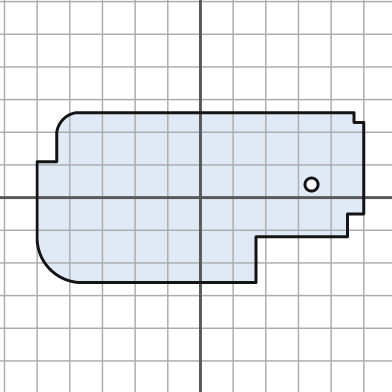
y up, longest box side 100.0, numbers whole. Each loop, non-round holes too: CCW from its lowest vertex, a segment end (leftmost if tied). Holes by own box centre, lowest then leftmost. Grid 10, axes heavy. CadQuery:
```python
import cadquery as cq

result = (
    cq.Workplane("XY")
    .moveTo(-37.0, -26.0)
    .lineTo(17.0, -26.0)
    .lineTo(17.0, -12.0)
    .lineTo(45.0, -12.0)
    .lineTo(45.0, -5.0)
    .lineTo(50.0, -5.0)
    .lineTo(50.0, 23.0)
    .lineTo(47.0, 23.0)
    .lineTo(47.0, 26.0)
    .lineTo(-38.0, 26.0)
    .threePointArc((-42.0, 24.0), (-44.0, 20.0))
    .lineTo(-44.0, 11.0)
    .lineTo(-50.0, 11.0)
    .lineTo(-50.0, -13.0)
    .threePointArc((-46.0, -22.0), (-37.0, -26.0))
    .close()
    .moveTo(34.0, 4.0)
    .circle(2.0)
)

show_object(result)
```